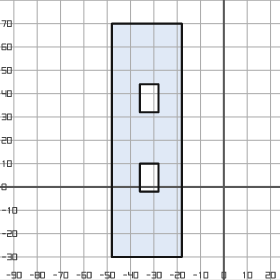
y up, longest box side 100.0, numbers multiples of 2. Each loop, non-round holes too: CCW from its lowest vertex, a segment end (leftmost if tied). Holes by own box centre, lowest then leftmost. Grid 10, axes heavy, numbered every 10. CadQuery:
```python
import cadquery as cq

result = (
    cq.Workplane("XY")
    .moveTo(-48.0, -30.0)
    .lineTo(-18.0, -30.0)
    .lineTo(-18.0, 70.0)
    .lineTo(-48.0, 70.0)
    .close()
    .moveTo(-36.0, -2.0)
    .lineTo(-28.0, -2.0)
    .lineTo(-28.0, 10.0)
    .lineTo(-36.0, 10.0)
    .close()
    .moveTo(-36.0, 32.0)
    .lineTo(-28.0, 32.0)
    .lineTo(-28.0, 44.0)
    .lineTo(-36.0, 44.0)
    .close()
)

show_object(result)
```